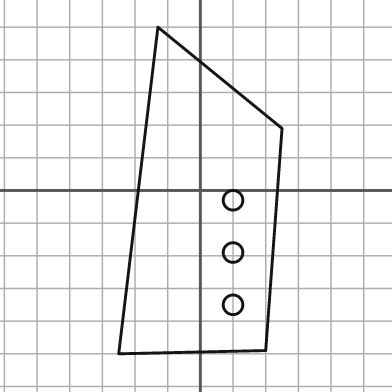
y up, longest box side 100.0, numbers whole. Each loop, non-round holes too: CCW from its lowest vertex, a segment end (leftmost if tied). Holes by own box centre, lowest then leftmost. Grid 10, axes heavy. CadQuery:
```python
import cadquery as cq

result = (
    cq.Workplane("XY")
    .moveTo(-25.0, -50.0)
    .lineTo(20.0, -49.0)
    .lineTo(25.0, 19.0)
    .lineTo(-13.0, 50.0)
    .close()
    .moveTo(10.0, -35.0)
    .circle(3.0)
    .moveTo(10.0, -19.0)
    .circle(3.0)
    .moveTo(10.0, -3.0)
    .circle(3.0)
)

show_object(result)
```